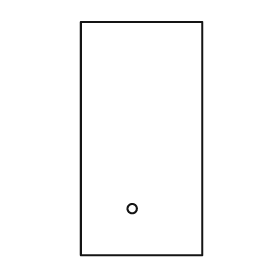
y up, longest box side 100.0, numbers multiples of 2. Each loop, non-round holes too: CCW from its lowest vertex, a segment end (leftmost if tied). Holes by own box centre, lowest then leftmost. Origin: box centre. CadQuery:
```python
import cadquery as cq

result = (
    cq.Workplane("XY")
    .moveTo(-26.0, -50.0)
    .lineTo(26.0, -50.0)
    .lineTo(26.0, 50.0)
    .lineTo(-26.0, 50.0)
    .close()
    .moveTo(-4.0, -30.0)
    .circle(2.0)
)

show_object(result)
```